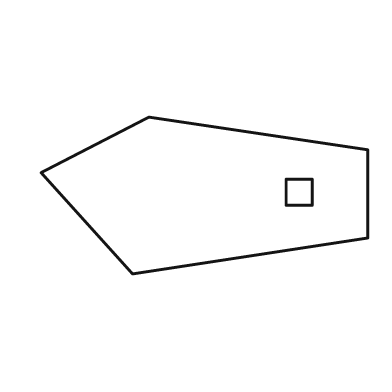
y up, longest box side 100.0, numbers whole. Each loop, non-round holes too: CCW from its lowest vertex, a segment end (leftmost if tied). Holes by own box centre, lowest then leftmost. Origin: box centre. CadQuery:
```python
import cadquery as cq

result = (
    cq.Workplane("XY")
    .moveTo(-22.0, -24.0)
    .lineTo(50.0, -13.0)
    .lineTo(50.0, 14.0)
    .lineTo(-17.0, 24.0)
    .lineTo(-50.0, 7.0)
    .close()
    .moveTo(25.0, -3.0)
    .lineTo(33.0, -3.0)
    .lineTo(33.0, 5.0)
    .lineTo(25.0, 5.0)
    .close()
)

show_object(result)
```